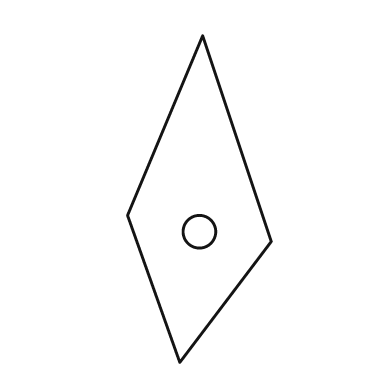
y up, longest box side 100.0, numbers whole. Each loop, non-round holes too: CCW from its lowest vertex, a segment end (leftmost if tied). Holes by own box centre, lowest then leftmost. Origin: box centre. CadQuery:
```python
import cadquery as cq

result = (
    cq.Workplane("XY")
    .moveTo(-6.0, -50.0)
    .lineTo(22.0, -13.0)
    .lineTo(1.0, 50.0)
    .lineTo(-22.0, -5.0)
    .close()
    .moveTo(0.0, -10.0)
    .circle(5.0)
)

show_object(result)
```